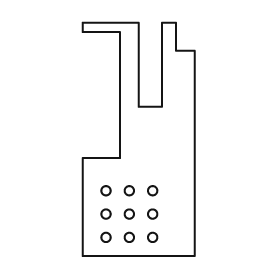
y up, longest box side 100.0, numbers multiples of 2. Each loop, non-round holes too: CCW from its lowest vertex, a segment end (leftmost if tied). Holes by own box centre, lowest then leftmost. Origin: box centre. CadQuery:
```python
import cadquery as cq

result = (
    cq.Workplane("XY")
    .moveTo(-24.0, -50.0)
    .lineTo(24.0, -50.0)
    .lineTo(24.0, 38.0)
    .lineTo(16.0, 38.0)
    .lineTo(16.0, 50.0)
    .lineTo(10.0, 50.0)
    .lineTo(10.0, 14.0)
    .lineTo(0.0, 14.0)
    .lineTo(0.0, 50.0)
    .lineTo(-24.0, 50.0)
    .lineTo(-24.0, 46.0)
    .lineTo(-8.0, 46.0)
    .lineTo(-8.0, -8.0)
    .lineTo(-24.0, -8.0)
    .close()
    .moveTo(-14.0, -42.0)
    .circle(2.0)
    .moveTo(-4.0, -42.0)
    .circle(2.0)
    .moveTo(6.0, -42.0)
    .circle(2.0)
    .moveTo(-14.0, -32.0)
    .circle(2.0)
    .moveTo(-4.0, -32.0)
    .circle(2.0)
    .moveTo(6.0, -32.0)
    .circle(2.0)
    .moveTo(-14.0, -22.0)
    .circle(2.0)
    .moveTo(-4.0, -22.0)
    .circle(2.0)
    .moveTo(6.0, -22.0)
    .circle(2.0)
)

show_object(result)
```